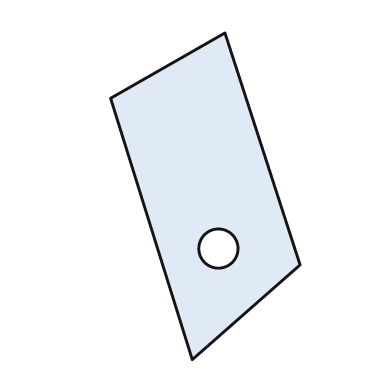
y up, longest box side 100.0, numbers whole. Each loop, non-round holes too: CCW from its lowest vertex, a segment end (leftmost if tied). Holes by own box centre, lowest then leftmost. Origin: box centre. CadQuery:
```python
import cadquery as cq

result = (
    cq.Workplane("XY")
    .moveTo(-4.0, -50.0)
    .lineTo(29.0, -21.0)
    .lineTo(6.0, 50.0)
    .lineTo(-29.0, 30.0)
    .close()
    .moveTo(4.0, -16.0)
    .circle(6.0)
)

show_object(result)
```